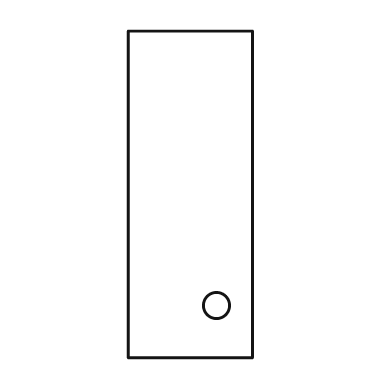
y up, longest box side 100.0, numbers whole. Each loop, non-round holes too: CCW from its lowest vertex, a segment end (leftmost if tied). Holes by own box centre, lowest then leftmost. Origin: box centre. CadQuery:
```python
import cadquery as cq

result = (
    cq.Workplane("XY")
    .moveTo(-19.0, -50.0)
    .lineTo(19.0, -50.0)
    .lineTo(19.0, 50.0)
    .lineTo(-19.0, 50.0)
    .close()
    .moveTo(8.0, -34.0)
    .circle(4.0)
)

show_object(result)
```